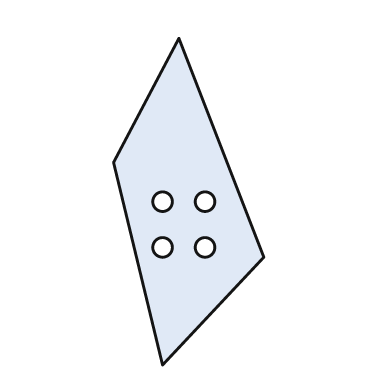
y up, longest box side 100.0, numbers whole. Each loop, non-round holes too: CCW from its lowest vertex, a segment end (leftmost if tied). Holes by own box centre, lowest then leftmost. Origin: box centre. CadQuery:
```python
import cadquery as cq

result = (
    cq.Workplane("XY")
    .moveTo(-8.0, -50.0)
    .lineTo(23.0, -17.0)
    .lineTo(-3.0, 50.0)
    .lineTo(-23.0, 12.0)
    .close()
    .moveTo(-8.0, -14.0)
    .circle(3.0)
    .moveTo(5.0, -14.0)
    .circle(3.0)
    .moveTo(-8.0, 0.0)
    .circle(3.0)
    .moveTo(5.0, 0.0)
    .circle(3.0)
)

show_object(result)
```